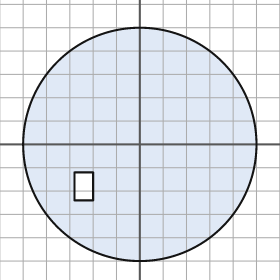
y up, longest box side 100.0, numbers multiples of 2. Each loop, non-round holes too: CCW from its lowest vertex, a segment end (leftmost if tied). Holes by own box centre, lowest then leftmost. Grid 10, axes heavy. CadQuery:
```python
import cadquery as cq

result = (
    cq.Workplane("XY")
    .moveTo(0.0, 0.0)
    .circle(50.0)
    .moveTo(-28.0, -24.0)
    .lineTo(-20.0, -24.0)
    .lineTo(-20.0, -12.0)
    .lineTo(-28.0, -12.0)
    .close()
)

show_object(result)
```